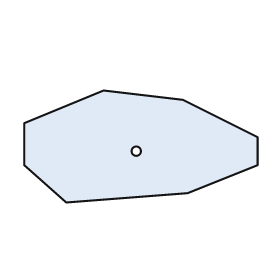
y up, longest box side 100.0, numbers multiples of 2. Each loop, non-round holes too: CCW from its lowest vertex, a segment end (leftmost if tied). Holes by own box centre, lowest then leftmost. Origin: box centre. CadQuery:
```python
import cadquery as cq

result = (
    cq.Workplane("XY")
    .moveTo(-32.0, -24.0)
    .lineTo(20.0, -20.0)
    .lineTo(50.0, -8.0)
    .lineTo(50.0, 4.0)
    .lineTo(18.0, 20.0)
    .lineTo(-16.0, 24.0)
    .lineTo(-50.0, 10.0)
    .lineTo(-50.0, -8.0)
    .close()
    .moveTo(-2.0, -2.0)
    .circle(2.0)
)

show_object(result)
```